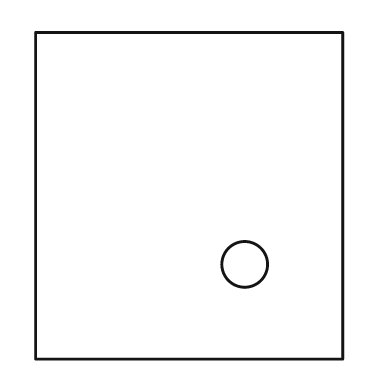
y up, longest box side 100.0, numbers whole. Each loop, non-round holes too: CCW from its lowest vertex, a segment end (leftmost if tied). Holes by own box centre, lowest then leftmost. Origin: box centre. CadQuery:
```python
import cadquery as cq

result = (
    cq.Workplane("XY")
    .moveTo(-47.0, -50.0)
    .lineTo(47.0, -50.0)
    .lineTo(47.0, 50.0)
    .lineTo(-47.0, 50.0)
    .close()
    .moveTo(17.0, -21.0)
    .circle(7.0)
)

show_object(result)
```